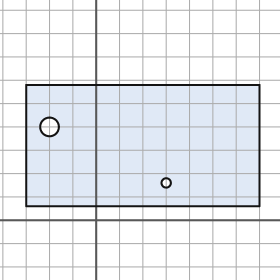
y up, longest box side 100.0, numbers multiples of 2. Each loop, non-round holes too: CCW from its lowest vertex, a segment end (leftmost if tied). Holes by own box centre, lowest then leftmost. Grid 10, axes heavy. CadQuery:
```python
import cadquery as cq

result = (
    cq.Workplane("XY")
    .moveTo(-30.0, 6.0)
    .lineTo(70.0, 6.0)
    .lineTo(70.0, 58.0)
    .lineTo(-30.0, 58.0)
    .close()
    .moveTo(30.0, 16.0)
    .circle(2.0)
    .moveTo(-20.0, 40.0)
    .circle(4.0)
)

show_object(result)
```